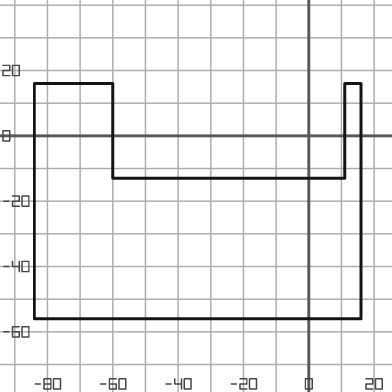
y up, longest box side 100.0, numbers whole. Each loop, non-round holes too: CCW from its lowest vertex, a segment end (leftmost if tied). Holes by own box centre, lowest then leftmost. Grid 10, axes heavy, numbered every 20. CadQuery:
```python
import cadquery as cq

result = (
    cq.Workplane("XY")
    .moveTo(-84.0, -56.0)
    .lineTo(16.0, -56.0)
    .lineTo(16.0, 16.0)
    .lineTo(11.0, 16.0)
    .lineTo(11.0, -13.0)
    .lineTo(-60.0, -13.0)
    .lineTo(-60.0, 16.0)
    .lineTo(-84.0, 16.0)
    .close()
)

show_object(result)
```